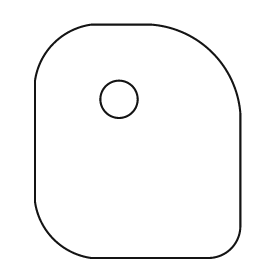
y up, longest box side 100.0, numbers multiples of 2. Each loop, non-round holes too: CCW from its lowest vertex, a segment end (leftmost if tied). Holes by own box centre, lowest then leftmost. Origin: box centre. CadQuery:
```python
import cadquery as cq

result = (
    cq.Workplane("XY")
    .moveTo(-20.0, -50.0)
    .lineTo(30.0, -50.0)
    .threePointArc((40.0, -46.0), (44.0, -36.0))
    .lineTo(44.0, 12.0)
    .threePointArc((32.0, 38.0), (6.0, 50.0))
    .lineTo(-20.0, 50.0)
    .threePointArc((-36.0, 42.0), (-44.0, 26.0))
    .lineTo(-44.0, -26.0)
    .threePointArc((-36.0, -42.0), (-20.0, -50.0))
    .close()
    .moveTo(-8.0, 18.0)
    .circle(8.0)
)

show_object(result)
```